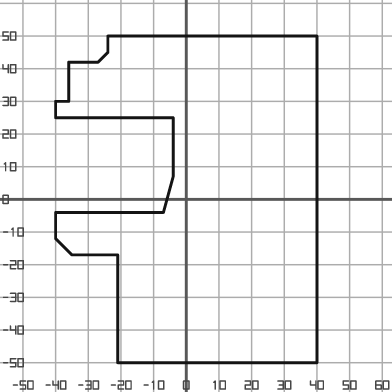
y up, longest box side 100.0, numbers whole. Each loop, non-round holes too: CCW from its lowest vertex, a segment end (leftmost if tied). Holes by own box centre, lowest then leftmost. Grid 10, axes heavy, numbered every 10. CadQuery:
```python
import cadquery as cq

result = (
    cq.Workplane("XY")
    .moveTo(-21.0, -50.0)
    .lineTo(40.0, -50.0)
    .lineTo(40.0, 50.0)
    .lineTo(-24.0, 50.0)
    .lineTo(-24.0, 45.0)
    .lineTo(-27.0, 42.0)
    .lineTo(-36.0, 42.0)
    .lineTo(-36.0, 30.0)
    .lineTo(-40.0, 30.0)
    .lineTo(-40.0, 25.0)
    .lineTo(-4.0, 25.0)
    .lineTo(-4.0, 7.0)
    .lineTo(-7.0, -4.0)
    .lineTo(-40.0, -4.0)
    .lineTo(-40.0, -12.0)
    .lineTo(-35.0, -17.0)
    .lineTo(-21.0, -17.0)
    .close()
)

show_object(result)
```